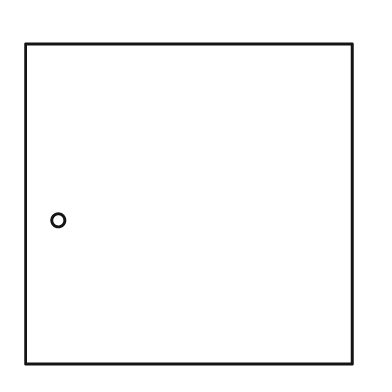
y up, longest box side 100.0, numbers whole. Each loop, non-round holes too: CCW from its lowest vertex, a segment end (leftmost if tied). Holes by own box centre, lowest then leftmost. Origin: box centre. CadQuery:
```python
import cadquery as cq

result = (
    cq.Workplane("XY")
    .moveTo(-50.0, -49.0)
    .lineTo(50.0, -49.0)
    .lineTo(50.0, 49.0)
    .lineTo(-50.0, 49.0)
    .close()
    .moveTo(-40.0, -5.0)
    .circle(2.0)
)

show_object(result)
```